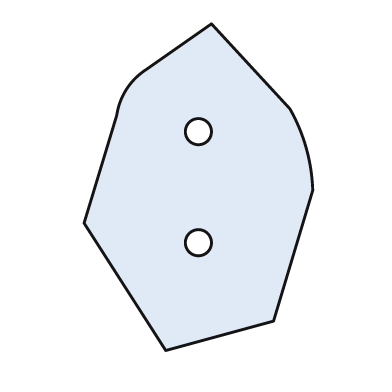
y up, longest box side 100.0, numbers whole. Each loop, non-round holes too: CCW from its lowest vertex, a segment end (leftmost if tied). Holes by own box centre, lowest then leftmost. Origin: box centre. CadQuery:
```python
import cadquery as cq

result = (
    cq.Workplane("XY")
    .moveTo(-10.0, -50.0)
    .lineTo(23.0, -41.0)
    .lineTo(35.0, -1.0)
    .threePointArc((33.0, 12.0), (28.0, 24.0))
    .lineTo(4.0, 50.0)
    .lineTo(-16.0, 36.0)
    .threePointArc((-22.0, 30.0), (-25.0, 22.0))
    .lineTo(-35.0, -11.0)
    .close()
    .moveTo(0.0, -17.0)
    .circle(4.0)
    .moveTo(0.0, 17.0)
    .circle(4.0)
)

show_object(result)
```